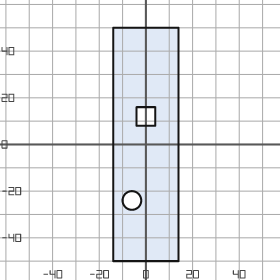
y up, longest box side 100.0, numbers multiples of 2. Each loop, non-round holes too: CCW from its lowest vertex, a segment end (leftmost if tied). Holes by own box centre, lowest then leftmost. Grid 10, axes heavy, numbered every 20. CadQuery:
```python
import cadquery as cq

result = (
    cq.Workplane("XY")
    .moveTo(-14.0, -50.0)
    .lineTo(14.0, -50.0)
    .lineTo(14.0, 50.0)
    .lineTo(-14.0, 50.0)
    .close()
    .moveTo(-6.0, -24.0)
    .circle(4.0)
    .moveTo(-4.0, 8.0)
    .lineTo(4.0, 8.0)
    .lineTo(4.0, 16.0)
    .lineTo(-4.0, 16.0)
    .close()
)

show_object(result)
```